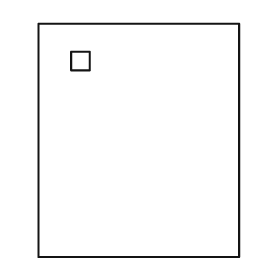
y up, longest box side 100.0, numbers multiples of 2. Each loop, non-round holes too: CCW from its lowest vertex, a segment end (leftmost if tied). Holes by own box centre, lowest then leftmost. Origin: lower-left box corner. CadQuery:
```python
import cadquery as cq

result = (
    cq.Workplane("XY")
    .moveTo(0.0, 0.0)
    .lineTo(86.0, 0.0)
    .lineTo(86.0, 100.0)
    .lineTo(0.0, 100.0)
    .close()
    .moveTo(14.0, 80.0)
    .lineTo(22.0, 80.0)
    .lineTo(22.0, 88.0)
    .lineTo(14.0, 88.0)
    .close()
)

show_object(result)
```